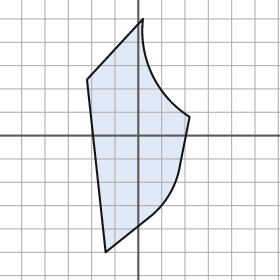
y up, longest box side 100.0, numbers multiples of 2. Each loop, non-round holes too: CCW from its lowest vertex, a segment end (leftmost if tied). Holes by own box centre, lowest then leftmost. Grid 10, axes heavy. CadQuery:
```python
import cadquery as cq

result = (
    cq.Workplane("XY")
    .moveTo(-14.0, -50.0)
    .lineTo(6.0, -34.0)
    .threePointArc((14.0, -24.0), (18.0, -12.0))
    .lineTo(22.0, 8.0)
    .threePointArc((6.0, 26.0), (2.0, 50.0))
    .lineTo(-22.0, 24.0)
    .close()
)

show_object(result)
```